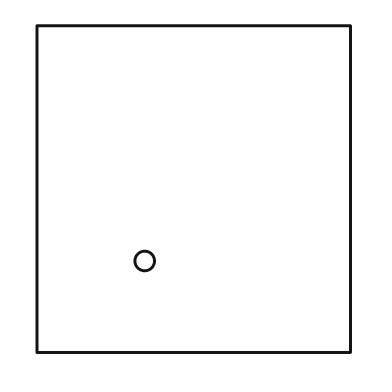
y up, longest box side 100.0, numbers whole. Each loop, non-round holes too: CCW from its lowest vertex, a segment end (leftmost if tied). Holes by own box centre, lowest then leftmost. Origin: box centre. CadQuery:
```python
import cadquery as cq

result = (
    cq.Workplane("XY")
    .moveTo(-48.0, -50.0)
    .lineTo(48.0, -50.0)
    .lineTo(48.0, 50.0)
    .lineTo(-48.0, 50.0)
    .close()
    .moveTo(-15.0, -22.0)
    .circle(3.0)
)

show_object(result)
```